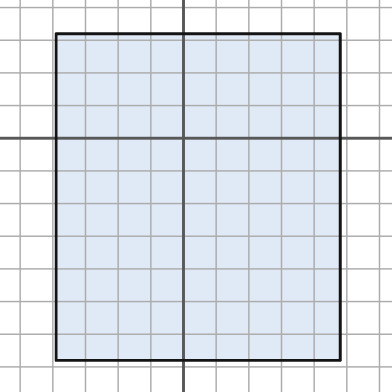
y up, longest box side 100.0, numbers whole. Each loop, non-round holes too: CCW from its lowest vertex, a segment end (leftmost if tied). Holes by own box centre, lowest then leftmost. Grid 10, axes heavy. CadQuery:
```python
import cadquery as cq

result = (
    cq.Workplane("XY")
    .moveTo(-39.0, -68.0)
    .lineTo(48.0, -68.0)
    .lineTo(48.0, 32.0)
    .lineTo(-39.0, 32.0)
    .close()
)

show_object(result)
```